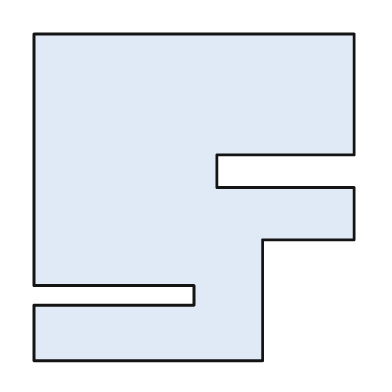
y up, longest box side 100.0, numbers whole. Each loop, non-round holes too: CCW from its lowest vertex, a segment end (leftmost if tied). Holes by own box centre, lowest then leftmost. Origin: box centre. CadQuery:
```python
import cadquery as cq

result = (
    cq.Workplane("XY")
    .moveTo(-49.0, -50.0)
    .lineTo(21.0, -50.0)
    .lineTo(21.0, -13.0)
    .lineTo(49.0, -13.0)
    .lineTo(49.0, 3.0)
    .lineTo(7.0, 3.0)
    .lineTo(7.0, 13.0)
    .lineTo(49.0, 13.0)
    .lineTo(49.0, 50.0)
    .lineTo(-49.0, 50.0)
    .lineTo(-49.0, -27.0)
    .lineTo(0.0, -27.0)
    .lineTo(0.0, -33.0)
    .lineTo(-49.0, -33.0)
    .close()
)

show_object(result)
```